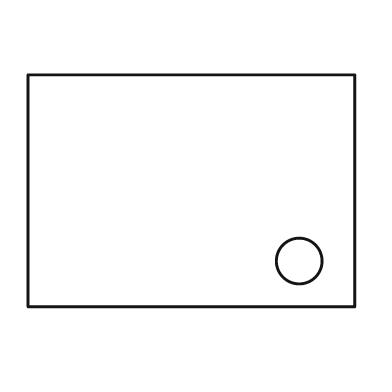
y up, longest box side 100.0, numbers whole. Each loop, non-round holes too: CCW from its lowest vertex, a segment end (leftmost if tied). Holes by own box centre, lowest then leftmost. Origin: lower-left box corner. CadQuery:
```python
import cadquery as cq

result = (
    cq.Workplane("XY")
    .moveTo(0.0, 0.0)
    .lineTo(100.0, 0.0)
    .lineTo(100.0, 71.0)
    .lineTo(0.0, 71.0)
    .close()
    .moveTo(83.0, 14.0)
    .circle(7.0)
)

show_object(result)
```